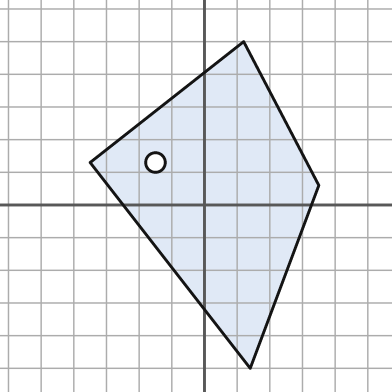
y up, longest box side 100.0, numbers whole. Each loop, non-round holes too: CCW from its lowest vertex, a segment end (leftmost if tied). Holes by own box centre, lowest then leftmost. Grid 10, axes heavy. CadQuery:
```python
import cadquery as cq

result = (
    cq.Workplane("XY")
    .moveTo(14.0, -50.0)
    .lineTo(35.0, 6.0)
    .lineTo(12.0, 50.0)
    .lineTo(-35.0, 13.0)
    .close()
    .moveTo(-15.0, 13.0)
    .circle(3.0)
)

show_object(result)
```